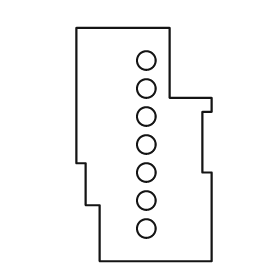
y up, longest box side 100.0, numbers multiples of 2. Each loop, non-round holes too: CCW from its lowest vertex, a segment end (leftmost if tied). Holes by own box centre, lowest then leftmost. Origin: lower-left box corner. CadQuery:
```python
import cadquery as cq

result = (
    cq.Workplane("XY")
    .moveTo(10.0, 0.0)
    .lineTo(58.0, 0.0)
    .lineTo(58.0, 38.0)
    .lineTo(54.0, 38.0)
    .lineTo(54.0, 64.0)
    .lineTo(58.0, 64.0)
    .lineTo(58.0, 70.0)
    .lineTo(40.0, 70.0)
    .lineTo(40.0, 100.0)
    .lineTo(0.0, 100.0)
    .lineTo(0.0, 42.0)
    .lineTo(4.0, 42.0)
    .lineTo(4.0, 24.0)
    .lineTo(10.0, 24.0)
    .close()
    .moveTo(30.0, 14.0)
    .circle(4.0)
    .moveTo(30.0, 26.0)
    .circle(4.0)
    .moveTo(30.0, 38.0)
    .circle(4.0)
    .moveTo(30.0, 50.0)
    .circle(4.0)
    .moveTo(30.0, 62.0)
    .circle(4.0)
    .moveTo(30.0, 74.0)
    .circle(4.0)
    .moveTo(30.0, 86.0)
    .circle(4.0)
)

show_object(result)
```